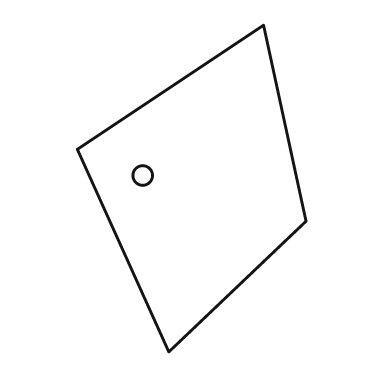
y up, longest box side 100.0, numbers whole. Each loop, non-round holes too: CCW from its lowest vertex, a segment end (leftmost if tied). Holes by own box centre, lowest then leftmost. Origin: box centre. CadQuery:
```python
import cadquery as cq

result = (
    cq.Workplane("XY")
    .moveTo(-7.0, -50.0)
    .lineTo(35.0, -10.0)
    .lineTo(22.0, 50.0)
    .lineTo(-35.0, 12.0)
    .close()
    .moveTo(-15.0, 4.0)
    .circle(3.0)
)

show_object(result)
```